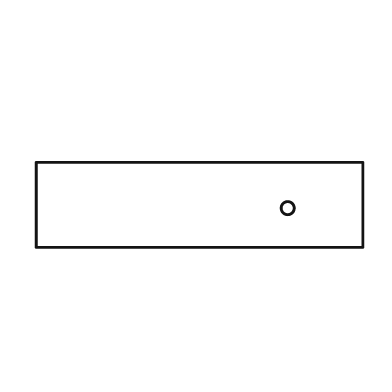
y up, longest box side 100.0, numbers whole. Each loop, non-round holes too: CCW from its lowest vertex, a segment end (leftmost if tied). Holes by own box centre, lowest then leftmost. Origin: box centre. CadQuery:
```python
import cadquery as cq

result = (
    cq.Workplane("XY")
    .moveTo(-50.0, -13.0)
    .lineTo(50.0, -13.0)
    .lineTo(50.0, 13.0)
    .lineTo(-50.0, 13.0)
    .close()
    .moveTo(27.0, -1.0)
    .circle(2.0)
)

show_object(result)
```